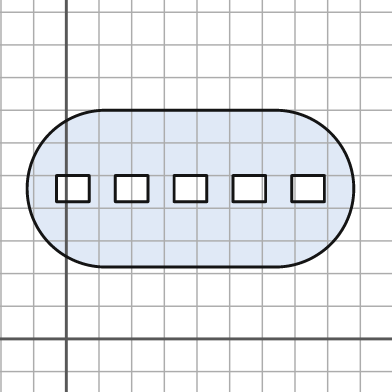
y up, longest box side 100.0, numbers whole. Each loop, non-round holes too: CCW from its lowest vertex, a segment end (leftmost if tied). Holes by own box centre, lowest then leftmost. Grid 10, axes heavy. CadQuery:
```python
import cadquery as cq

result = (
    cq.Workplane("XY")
    .moveTo(12.0, 22.0)
    .lineTo(64.0, 22.0)
    .threePointArc((88.0, 46.0), (64.0, 70.0))
    .lineTo(12.0, 70.0)
    .threePointArc((-12.0, 46.0), (12.0, 22.0))
    .close()
    .moveTo(-3.0, 42.0)
    .lineTo(7.0, 42.0)
    .lineTo(7.0, 50.0)
    .lineTo(-3.0, 50.0)
    .close()
    .moveTo(15.0, 42.0)
    .lineTo(25.0, 42.0)
    .lineTo(25.0, 50.0)
    .lineTo(15.0, 50.0)
    .close()
    .moveTo(33.0, 42.0)
    .lineTo(43.0, 42.0)
    .lineTo(43.0, 50.0)
    .lineTo(33.0, 50.0)
    .close()
    .moveTo(51.0, 42.0)
    .lineTo(61.0, 42.0)
    .lineTo(61.0, 50.0)
    .lineTo(51.0, 50.0)
    .close()
    .moveTo(69.0, 42.0)
    .lineTo(79.0, 42.0)
    .lineTo(79.0, 50.0)
    .lineTo(69.0, 50.0)
    .close()
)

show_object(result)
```